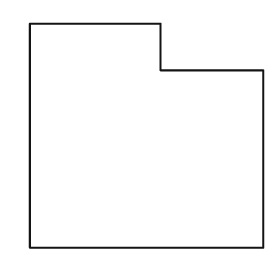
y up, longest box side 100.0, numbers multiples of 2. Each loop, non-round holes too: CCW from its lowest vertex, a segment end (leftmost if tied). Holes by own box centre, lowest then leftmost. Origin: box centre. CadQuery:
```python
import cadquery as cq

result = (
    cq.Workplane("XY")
    .moveTo(-50.0, -48.0)
    .lineTo(50.0, -48.0)
    .lineTo(50.0, 28.0)
    .lineTo(6.0, 28.0)
    .lineTo(6.0, 48.0)
    .lineTo(-50.0, 48.0)
    .close()
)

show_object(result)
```